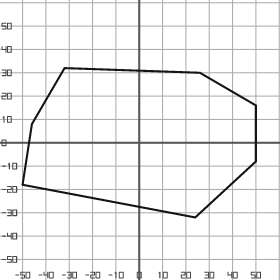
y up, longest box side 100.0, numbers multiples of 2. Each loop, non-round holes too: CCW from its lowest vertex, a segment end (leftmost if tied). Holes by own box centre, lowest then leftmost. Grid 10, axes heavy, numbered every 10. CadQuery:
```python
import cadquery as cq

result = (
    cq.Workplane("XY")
    .moveTo(24.0, -32.0)
    .lineTo(50.0, -8.0)
    .lineTo(50.0, 16.0)
    .lineTo(26.0, 30.0)
    .lineTo(-32.0, 32.0)
    .lineTo(-46.0, 8.0)
    .lineTo(-50.0, -18.0)
    .close()
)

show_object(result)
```